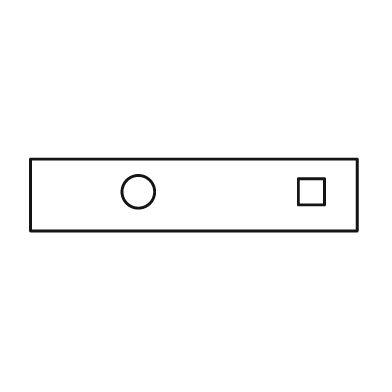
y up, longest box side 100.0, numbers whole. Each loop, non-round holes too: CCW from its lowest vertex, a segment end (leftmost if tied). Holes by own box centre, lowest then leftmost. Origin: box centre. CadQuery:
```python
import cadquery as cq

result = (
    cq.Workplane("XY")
    .moveTo(-50.0, -11.0)
    .lineTo(50.0, -11.0)
    .lineTo(50.0, 11.0)
    .lineTo(-50.0, 11.0)
    .close()
    .moveTo(-17.0, 1.0)
    .circle(5.0)
    .moveTo(32.0, -3.0)
    .lineTo(40.0, -3.0)
    .lineTo(40.0, 5.0)
    .lineTo(32.0, 5.0)
    .close()
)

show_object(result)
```